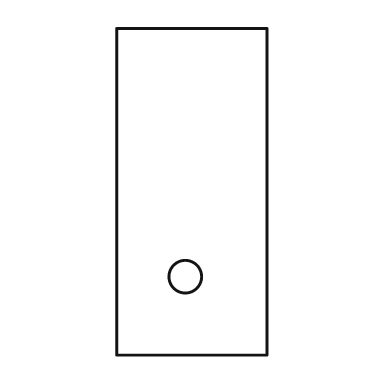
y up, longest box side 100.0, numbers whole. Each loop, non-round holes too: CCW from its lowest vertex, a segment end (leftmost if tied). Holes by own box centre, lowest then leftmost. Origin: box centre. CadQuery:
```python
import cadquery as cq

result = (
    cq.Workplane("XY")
    .moveTo(-23.0, -50.0)
    .lineTo(23.0, -50.0)
    .lineTo(23.0, 50.0)
    .lineTo(-23.0, 50.0)
    .close()
    .moveTo(-2.0, -26.0)
    .circle(5.0)
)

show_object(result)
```